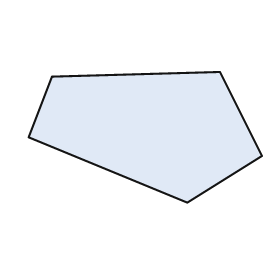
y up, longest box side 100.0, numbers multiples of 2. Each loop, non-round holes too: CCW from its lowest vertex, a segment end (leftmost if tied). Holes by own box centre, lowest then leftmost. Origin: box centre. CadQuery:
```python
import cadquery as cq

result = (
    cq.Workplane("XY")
    .moveTo(18.0, -28.0)
    .lineTo(50.0, -8.0)
    .lineTo(32.0, 28.0)
    .lineTo(-40.0, 26.0)
    .lineTo(-50.0, 0.0)
    .close()
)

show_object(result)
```